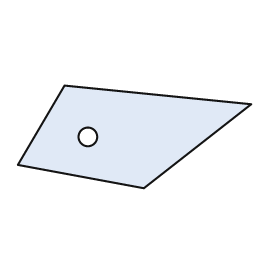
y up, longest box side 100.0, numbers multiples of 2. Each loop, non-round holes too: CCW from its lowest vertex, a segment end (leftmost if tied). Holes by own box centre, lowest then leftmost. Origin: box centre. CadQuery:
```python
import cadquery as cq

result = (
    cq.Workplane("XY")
    .moveTo(4.0, -22.0)
    .lineTo(50.0, 14.0)
    .lineTo(-30.0, 22.0)
    .lineTo(-50.0, -12.0)
    .close()
    .moveTo(-20.0, 0.0)
    .circle(4.0)
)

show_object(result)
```